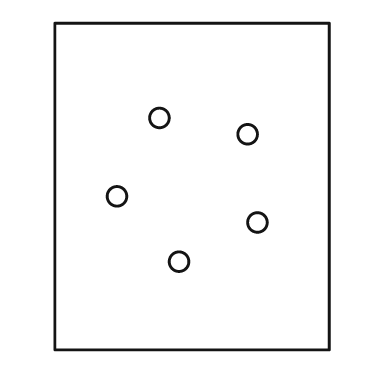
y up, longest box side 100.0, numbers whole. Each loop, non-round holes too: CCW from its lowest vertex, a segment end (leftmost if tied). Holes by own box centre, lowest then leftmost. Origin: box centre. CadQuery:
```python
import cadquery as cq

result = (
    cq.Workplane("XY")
    .moveTo(-42.0, -50.0)
    .lineTo(42.0, -50.0)
    .lineTo(42.0, 50.0)
    .lineTo(-42.0, 50.0)
    .close()
    .moveTo(-4.0, -23.0)
    .circle(3.0)
    .moveTo(20.0, -11.0)
    .circle(3.0)
    .moveTo(-23.0, -3.0)
    .circle(3.0)
    .moveTo(17.0, 16.0)
    .circle(3.0)
    .moveTo(-10.0, 21.0)
    .circle(3.0)
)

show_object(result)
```